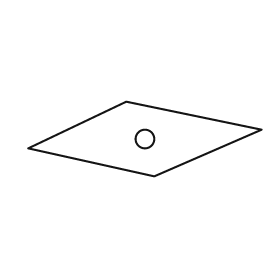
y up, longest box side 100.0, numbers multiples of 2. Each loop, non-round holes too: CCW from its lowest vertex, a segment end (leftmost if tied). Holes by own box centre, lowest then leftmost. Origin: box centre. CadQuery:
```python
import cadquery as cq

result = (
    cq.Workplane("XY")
    .moveTo(4.0, -16.0)
    .lineTo(50.0, 4.0)
    .lineTo(-8.0, 16.0)
    .lineTo(-50.0, -4.0)
    .close()
    .moveTo(0.0, 0.0)
    .circle(4.0)
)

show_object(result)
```